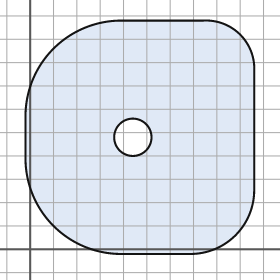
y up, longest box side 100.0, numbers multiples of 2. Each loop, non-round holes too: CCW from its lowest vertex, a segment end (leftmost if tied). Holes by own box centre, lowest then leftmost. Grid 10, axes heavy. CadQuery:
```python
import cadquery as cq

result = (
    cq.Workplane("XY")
    .moveTo(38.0, -2.0)
    .lineTo(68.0, -2.0)
    .threePointArc((88.0, 6.0), (96.0, 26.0))
    .lineTo(96.0, 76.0)
    .threePointArc((90.0, 92.0), (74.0, 98.0))
    .lineTo(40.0, 98.0)
    .threePointArc((10.0, 86.0), (-2.0, 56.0))
    .lineTo(-2.0, 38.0)
    .threePointArc((10.0, 10.0), (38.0, -2.0))
    .close()
    .moveTo(44.0, 48.0)
    .circle(8.0)
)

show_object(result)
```